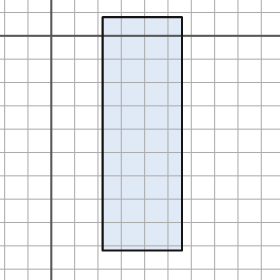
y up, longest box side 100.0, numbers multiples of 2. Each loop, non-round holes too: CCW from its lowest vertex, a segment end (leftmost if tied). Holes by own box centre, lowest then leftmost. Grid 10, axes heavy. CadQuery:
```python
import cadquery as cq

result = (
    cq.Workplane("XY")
    .moveTo(22.0, -92.0)
    .lineTo(56.0, -92.0)
    .lineTo(56.0, 8.0)
    .lineTo(22.0, 8.0)
    .close()
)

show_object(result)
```